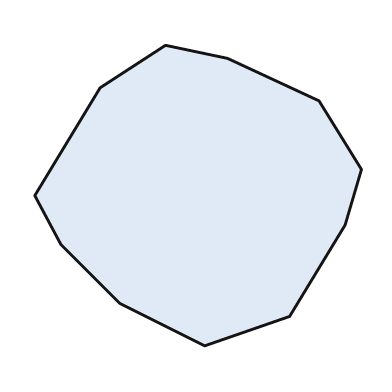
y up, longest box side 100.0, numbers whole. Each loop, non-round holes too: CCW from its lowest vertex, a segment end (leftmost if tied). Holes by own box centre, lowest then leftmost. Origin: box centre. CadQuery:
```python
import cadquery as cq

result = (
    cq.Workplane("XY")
    .moveTo(2.0, -46.0)
    .lineTo(28.0, -37.0)
    .lineTo(45.0, -9.0)
    .lineTo(50.0, 8.0)
    .lineTo(37.0, 29.0)
    .lineTo(9.0, 42.0)
    .lineTo(-10.0, 46.0)
    .lineTo(-30.0, 33.0)
    .lineTo(-50.0, 0.0)
    .lineTo(-42.0, -15.0)
    .lineTo(-24.0, -33.0)
    .close()
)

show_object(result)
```